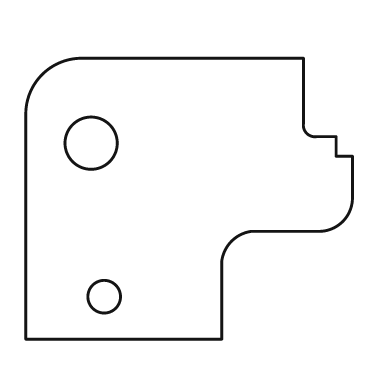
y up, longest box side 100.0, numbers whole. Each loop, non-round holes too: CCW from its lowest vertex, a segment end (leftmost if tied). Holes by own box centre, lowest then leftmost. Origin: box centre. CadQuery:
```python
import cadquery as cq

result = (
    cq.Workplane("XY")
    .moveTo(-50.0, -43.0)
    .lineTo(10.0, -43.0)
    .lineTo(10.0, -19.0)
    .threePointArc((13.0, -13.0), (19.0, -10.0))
    .lineTo(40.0, -10.0)
    .threePointArc((47.0, -7.0), (50.0, 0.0))
    .lineTo(50.0, 13.0)
    .lineTo(45.0, 13.0)
    .lineTo(45.0, 19.0)
    .lineTo(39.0, 19.0)
    .threePointArc((36.0, 20.0), (35.0, 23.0))
    .lineTo(35.0, 43.0)
    .lineTo(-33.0, 43.0)
    .threePointArc((-45.0, 38.0), (-50.0, 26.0))
    .close()
    .moveTo(-26.0, -30.0)
    .circle(5.0)
    .moveTo(-30.0, 17.0)
    .circle(8.0)
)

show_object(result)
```